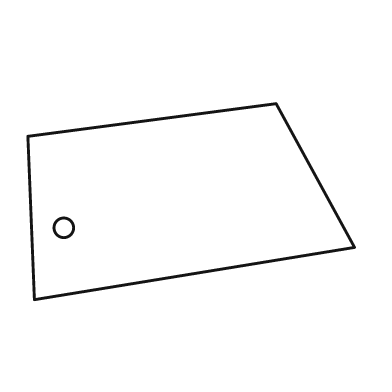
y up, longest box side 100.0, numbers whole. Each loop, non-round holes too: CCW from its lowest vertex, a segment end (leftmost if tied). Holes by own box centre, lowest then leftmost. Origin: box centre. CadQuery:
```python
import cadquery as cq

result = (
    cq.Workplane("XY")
    .moveTo(-48.0, -30.0)
    .lineTo(50.0, -14.0)
    .lineTo(26.0, 30.0)
    .lineTo(-50.0, 20.0)
    .close()
    .moveTo(-39.0, -8.0)
    .circle(3.0)
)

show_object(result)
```